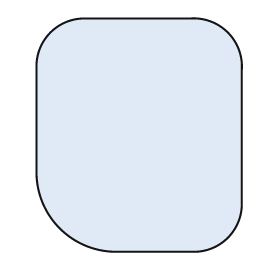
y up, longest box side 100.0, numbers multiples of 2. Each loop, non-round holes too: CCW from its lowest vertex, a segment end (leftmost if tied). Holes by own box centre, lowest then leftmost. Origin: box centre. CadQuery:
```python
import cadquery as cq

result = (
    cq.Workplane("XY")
    .moveTo(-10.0, -50.0)
    .lineTo(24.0, -50.0)
    .threePointArc((38.0, -44.0), (44.0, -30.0))
    .lineTo(44.0, 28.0)
    .threePointArc((38.0, 44.0), (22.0, 50.0))
    .lineTo(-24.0, 50.0)
    .threePointArc((-38.0, 44.0), (-44.0, 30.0))
    .lineTo(-44.0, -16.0)
    .threePointArc((-34.0, -40.0), (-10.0, -50.0))
    .close()
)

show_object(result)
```